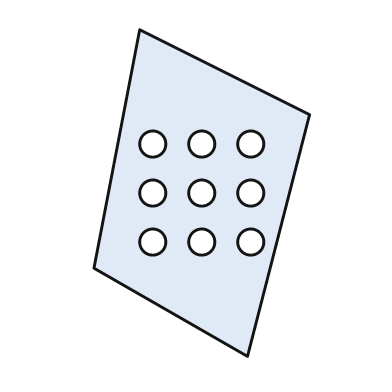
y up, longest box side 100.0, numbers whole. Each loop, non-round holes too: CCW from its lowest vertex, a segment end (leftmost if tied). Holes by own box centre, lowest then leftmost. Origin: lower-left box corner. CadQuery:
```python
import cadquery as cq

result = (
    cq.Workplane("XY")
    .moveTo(47.0, 0.0)
    .lineTo(66.0, 74.0)
    .lineTo(14.0, 100.0)
    .lineTo(0.0, 27.0)
    .close()
    .moveTo(18.0, 35.0)
    .circle(4.0)
    .moveTo(33.0, 35.0)
    .circle(4.0)
    .moveTo(48.0, 35.0)
    .circle(4.0)
    .moveTo(18.0, 50.0)
    .circle(4.0)
    .moveTo(33.0, 50.0)
    .circle(4.0)
    .moveTo(48.0, 50.0)
    .circle(4.0)
    .moveTo(18.0, 65.0)
    .circle(4.0)
    .moveTo(33.0, 65.0)
    .circle(4.0)
    .moveTo(48.0, 65.0)
    .circle(4.0)
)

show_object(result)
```